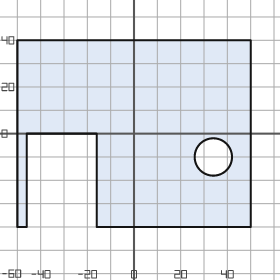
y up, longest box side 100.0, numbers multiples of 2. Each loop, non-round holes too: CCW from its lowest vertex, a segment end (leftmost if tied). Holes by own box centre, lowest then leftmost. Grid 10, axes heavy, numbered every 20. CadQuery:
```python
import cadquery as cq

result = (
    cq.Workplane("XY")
    .moveTo(-50.0, -40.0)
    .lineTo(-46.0, -40.0)
    .lineTo(-46.0, 0.0)
    .lineTo(-16.0, 0.0)
    .lineTo(-16.0, -40.0)
    .lineTo(50.0, -40.0)
    .lineTo(50.0, 40.0)
    .lineTo(-50.0, 40.0)
    .close()
    .moveTo(34.0, -10.0)
    .circle(8.0)
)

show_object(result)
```